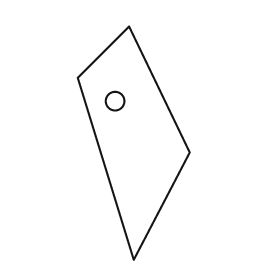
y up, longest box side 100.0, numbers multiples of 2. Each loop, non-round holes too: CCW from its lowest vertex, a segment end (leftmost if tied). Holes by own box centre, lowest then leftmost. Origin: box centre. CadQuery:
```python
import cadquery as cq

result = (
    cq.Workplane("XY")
    .moveTo(0.0, -50.0)
    .lineTo(24.0, -4.0)
    .lineTo(-2.0, 50.0)
    .lineTo(-24.0, 28.0)
    .close()
    .moveTo(-8.0, 18.0)
    .circle(4.0)
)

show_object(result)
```